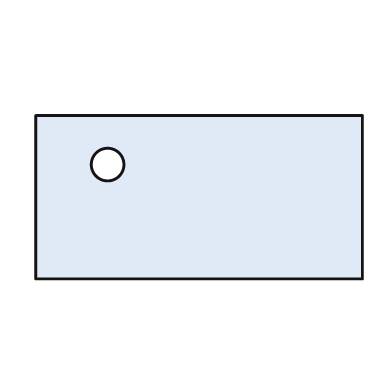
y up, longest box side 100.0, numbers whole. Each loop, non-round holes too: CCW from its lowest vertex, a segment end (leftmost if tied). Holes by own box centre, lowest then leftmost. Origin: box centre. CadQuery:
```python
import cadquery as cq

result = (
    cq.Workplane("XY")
    .moveTo(-50.0, -25.0)
    .lineTo(50.0, -25.0)
    .lineTo(50.0, 25.0)
    .lineTo(-50.0, 25.0)
    .close()
    .moveTo(-28.0, 10.0)
    .circle(5.0)
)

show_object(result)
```